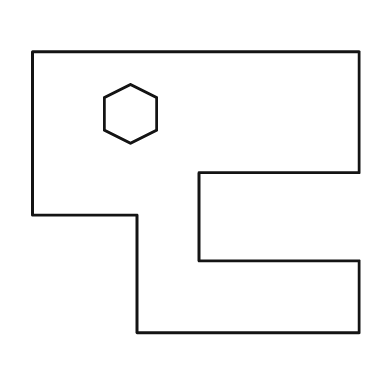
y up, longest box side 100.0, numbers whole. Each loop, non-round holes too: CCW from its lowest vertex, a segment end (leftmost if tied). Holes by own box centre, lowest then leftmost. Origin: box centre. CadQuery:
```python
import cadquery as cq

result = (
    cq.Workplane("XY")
    .moveTo(-18.0, -43.0)
    .lineTo(50.0, -43.0)
    .lineTo(50.0, -21.0)
    .lineTo(1.0, -21.0)
    .lineTo(1.0, 6.0)
    .lineTo(50.0, 6.0)
    .lineTo(50.0, 43.0)
    .lineTo(-50.0, 43.0)
    .lineTo(-50.0, -7.0)
    .lineTo(-18.0, -7.0)
    .close()
    .moveTo(-20.0, 15.0)
    .lineTo(-12.0, 19.0)
    .lineTo(-12.0, 29.0)
    .lineTo(-20.0, 33.0)
    .lineTo(-28.0, 29.0)
    .lineTo(-28.0, 19.0)
    .close()
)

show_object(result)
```